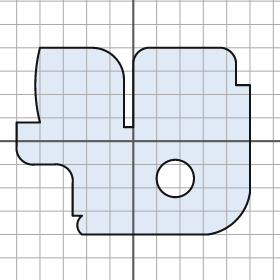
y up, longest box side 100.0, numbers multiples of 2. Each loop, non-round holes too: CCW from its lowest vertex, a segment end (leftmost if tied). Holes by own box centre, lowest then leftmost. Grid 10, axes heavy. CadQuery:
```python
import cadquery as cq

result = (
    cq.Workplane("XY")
    .moveTo(-22.0, -40.0)
    .lineTo(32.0, -40.0)
    .threePointArc((44.0, -34.0), (50.0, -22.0))
    .lineTo(50.0, 24.0)
    .lineTo(44.0, 24.0)
    .lineTo(44.0, 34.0)
    .threePointArc((42.0, 38.0), (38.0, 40.0))
    .lineTo(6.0, 40.0)
    .threePointArc((2.0, 38.0), (0.0, 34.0))
    .lineTo(0.0, 6.0)
    .lineTo(-4.0, 6.0)
    .lineTo(-4.0, 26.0)
    .threePointArc((-8.0, 36.0), (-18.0, 40.0))
    .lineTo(-40.0, 40.0)
    .threePointArc((-42.0, 24.0), (-40.0, 8.0))
    .lineTo(-50.0, 8.0)
    .lineTo(-50.0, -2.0)
    .threePointArc((-48.0, -8.0), (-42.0, -10.0))
    .lineTo(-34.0, -10.0)
    .threePointArc((-28.0, -12.0), (-26.0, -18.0))
    .lineTo(-26.0, -32.0)
    .lineTo(-22.0, -32.0)
    .threePointArc((-24.0, -36.0), (-22.0, -40.0))
    .close()
    .moveTo(18.0, -16.0)
    .circle(8.0)
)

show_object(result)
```